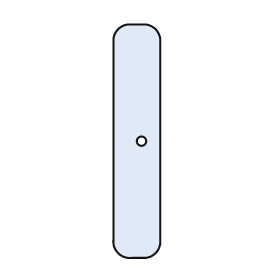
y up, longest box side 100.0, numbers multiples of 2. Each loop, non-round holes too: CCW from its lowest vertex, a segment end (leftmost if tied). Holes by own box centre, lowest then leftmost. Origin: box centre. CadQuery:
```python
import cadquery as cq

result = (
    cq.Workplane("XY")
    .moveTo(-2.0, -50.0)
    .lineTo(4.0, -50.0)
    .threePointArc((8.0, -48.0), (10.0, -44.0))
    .lineTo(10.0, 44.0)
    .threePointArc((8.0, 48.0), (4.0, 50.0))
    .lineTo(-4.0, 50.0)
    .threePointArc((-8.0, 48.0), (-10.0, 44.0))
    .lineTo(-10.0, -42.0)
    .threePointArc((-8.0, -48.0), (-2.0, -50.0))
    .close()
    .moveTo(2.0, 0.0)
    .circle(2.0)
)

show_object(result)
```